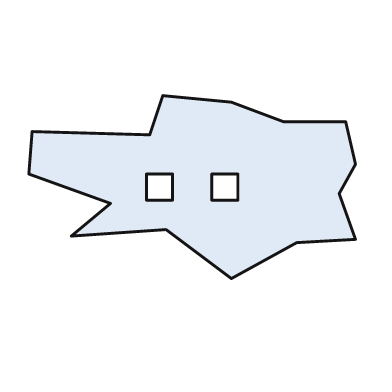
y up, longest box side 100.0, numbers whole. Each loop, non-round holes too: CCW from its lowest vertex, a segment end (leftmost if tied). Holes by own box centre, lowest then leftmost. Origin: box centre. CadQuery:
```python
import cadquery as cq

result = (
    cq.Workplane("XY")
    .moveTo(12.0, -28.0)
    .lineTo(32.0, -17.0)
    .lineTo(50.0, -16.0)
    .lineTo(45.0, -2.0)
    .lineTo(50.0, 7.0)
    .lineTo(47.0, 20.0)
    .lineTo(28.0, 20.0)
    .lineTo(12.0, 26.0)
    .lineTo(-9.0, 28.0)
    .lineTo(-13.0, 16.0)
    .lineTo(-49.0, 17.0)
    .lineTo(-50.0, 4.0)
    .lineTo(-25.0, -5.0)
    .lineTo(-37.0, -15.0)
    .lineTo(-8.0, -13.0)
    .close()
    .moveTo(-14.0, -4.0)
    .lineTo(-6.0, -4.0)
    .lineTo(-6.0, 4.0)
    .lineTo(-14.0, 4.0)
    .close()
    .moveTo(6.0, -4.0)
    .lineTo(14.0, -4.0)
    .lineTo(14.0, 4.0)
    .lineTo(6.0, 4.0)
    .close()
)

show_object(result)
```